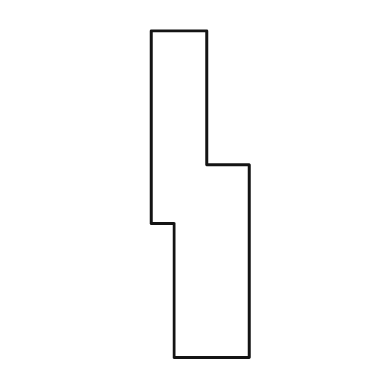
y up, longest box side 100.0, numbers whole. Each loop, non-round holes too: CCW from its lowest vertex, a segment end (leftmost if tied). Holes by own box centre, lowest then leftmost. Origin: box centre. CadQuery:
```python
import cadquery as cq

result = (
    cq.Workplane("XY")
    .moveTo(-8.0, -50.0)
    .lineTo(15.0, -50.0)
    .lineTo(15.0, 9.0)
    .lineTo(2.0, 9.0)
    .lineTo(2.0, 50.0)
    .lineTo(-15.0, 50.0)
    .lineTo(-15.0, -9.0)
    .lineTo(-8.0, -9.0)
    .close()
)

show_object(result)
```